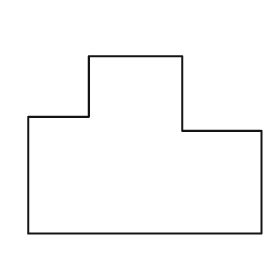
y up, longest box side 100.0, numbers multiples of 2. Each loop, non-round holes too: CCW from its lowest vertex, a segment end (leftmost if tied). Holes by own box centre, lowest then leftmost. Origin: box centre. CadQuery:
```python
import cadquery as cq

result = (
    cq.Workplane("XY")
    .moveTo(-50.0, -38.0)
    .lineTo(50.0, -38.0)
    .lineTo(50.0, 6.0)
    .lineTo(16.0, 6.0)
    .lineTo(16.0, 38.0)
    .lineTo(-24.0, 38.0)
    .lineTo(-24.0, 12.0)
    .lineTo(-50.0, 12.0)
    .close()
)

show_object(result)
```